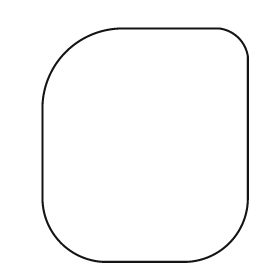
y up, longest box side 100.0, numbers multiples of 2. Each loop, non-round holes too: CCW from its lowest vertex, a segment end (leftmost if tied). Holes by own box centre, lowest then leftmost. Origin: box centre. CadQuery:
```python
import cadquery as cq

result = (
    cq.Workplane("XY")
    .moveTo(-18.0, -50.0)
    .lineTo(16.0, -50.0)
    .threePointArc((36.0, -42.0), (44.0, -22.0))
    .lineTo(44.0, 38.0)
    .threePointArc((40.0, 46.0), (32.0, 50.0))
    .lineTo(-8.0, 50.0)
    .threePointArc((-34.0, 40.0), (-44.0, 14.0))
    .lineTo(-44.0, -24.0)
    .threePointArc((-36.0, -42.0), (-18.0, -50.0))
    .close()
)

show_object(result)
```